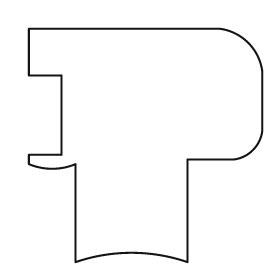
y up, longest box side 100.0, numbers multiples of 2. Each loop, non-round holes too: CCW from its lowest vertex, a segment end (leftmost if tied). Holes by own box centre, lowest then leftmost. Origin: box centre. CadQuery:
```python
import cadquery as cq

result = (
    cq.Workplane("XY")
    .moveTo(-30.0, -50.0)
    .threePointArc((-6.0, -46.0), (18.0, -50.0))
    .lineTo(18.0, -6.0)
    .lineTo(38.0, -6.0)
    .threePointArc((46.0, -2.0), (50.0, 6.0))
    .lineTo(50.0, 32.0)
    .threePointArc((44.0, 44.0), (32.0, 50.0))
    .lineTo(-50.0, 50.0)
    .lineTo(-50.0, 30.0)
    .lineTo(-36.0, 30.0)
    .lineTo(-36.0, -4.0)
    .lineTo(-50.0, -4.0)
    .lineTo(-50.0, -8.0)
    .threePointArc((-40.0, -10.0), (-30.0, -8.0))
    .close()
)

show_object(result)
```